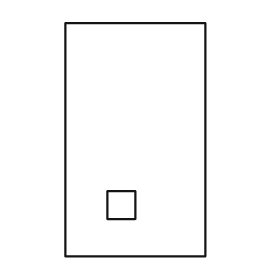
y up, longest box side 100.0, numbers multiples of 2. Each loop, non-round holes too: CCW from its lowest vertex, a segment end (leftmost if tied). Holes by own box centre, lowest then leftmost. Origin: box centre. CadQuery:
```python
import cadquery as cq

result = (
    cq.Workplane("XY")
    .moveTo(-30.0, -50.0)
    .lineTo(30.0, -50.0)
    .lineTo(30.0, 50.0)
    .lineTo(-30.0, 50.0)
    .close()
    .moveTo(-12.0, -34.0)
    .lineTo(0.0, -34.0)
    .lineTo(0.0, -22.0)
    .lineTo(-12.0, -22.0)
    .close()
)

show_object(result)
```